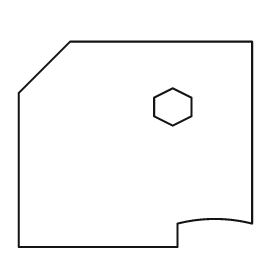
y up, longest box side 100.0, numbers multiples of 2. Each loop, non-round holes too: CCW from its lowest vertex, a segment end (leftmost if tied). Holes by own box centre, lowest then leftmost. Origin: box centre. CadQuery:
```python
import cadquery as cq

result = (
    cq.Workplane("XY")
    .moveTo(-50.0, -44.0)
    .lineTo(18.0, -44.0)
    .lineTo(18.0, -34.0)
    .threePointArc((34.0, -32.0), (50.0, -34.0))
    .lineTo(50.0, 44.0)
    .lineTo(-28.0, 44.0)
    .lineTo(-50.0, 22.0)
    .close()
    .moveTo(16.0, 8.0)
    .lineTo(24.0, 12.0)
    .lineTo(24.0, 20.0)
    .lineTo(16.0, 24.0)
    .lineTo(8.0, 20.0)
    .lineTo(8.0, 12.0)
    .close()
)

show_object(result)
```